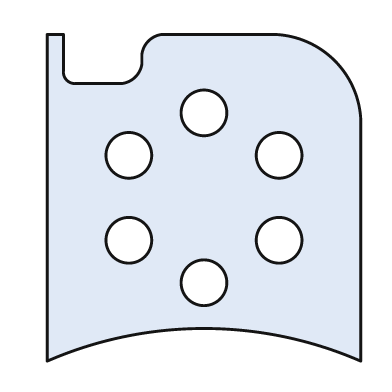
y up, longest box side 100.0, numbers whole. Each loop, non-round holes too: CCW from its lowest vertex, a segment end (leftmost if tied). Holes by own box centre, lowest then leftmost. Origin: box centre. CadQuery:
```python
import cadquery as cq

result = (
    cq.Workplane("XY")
    .moveTo(-48.0, -50.0)
    .threePointArc((0.0, -40.0), (48.0, -50.0))
    .lineTo(48.0, 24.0)
    .threePointArc((40.0, 42.0), (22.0, 50.0))
    .lineTo(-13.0, 50.0)
    .threePointArc((-17.0, 48.0), (-19.0, 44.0))
    .lineTo(-19.0, 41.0)
    .threePointArc((-21.0, 37.0), (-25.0, 35.0))
    .lineTo(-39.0, 35.0)
    .threePointArc((-42.0, 36.0), (-43.0, 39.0))
    .lineTo(-43.0, 50.0)
    .lineTo(-48.0, 50.0)
    .close()
    .moveTo(0.0, -26.0)
    .circle(7.0)
    .moveTo(-23.0, -13.0)
    .circle(7.0)
    .moveTo(23.0, -13.0)
    .circle(7.0)
    .moveTo(-23.0, 13.0)
    .circle(7.0)
    .moveTo(23.0, 13.0)
    .circle(7.0)
    .moveTo(0.0, 26.0)
    .circle(7.0)
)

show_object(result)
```